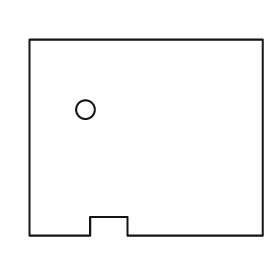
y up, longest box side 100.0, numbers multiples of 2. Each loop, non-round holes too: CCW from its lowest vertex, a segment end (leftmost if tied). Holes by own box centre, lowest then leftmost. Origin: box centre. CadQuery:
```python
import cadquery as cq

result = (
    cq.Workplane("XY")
    .moveTo(-50.0, -42.0)
    .lineTo(-24.0, -42.0)
    .lineTo(-24.0, -34.0)
    .lineTo(-8.0, -34.0)
    .lineTo(-8.0, -42.0)
    .lineTo(50.0, -42.0)
    .lineTo(50.0, 42.0)
    .lineTo(-50.0, 42.0)
    .close()
    .moveTo(-26.0, 12.0)
    .circle(4.0)
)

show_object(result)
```